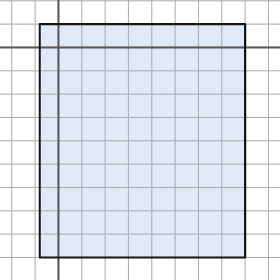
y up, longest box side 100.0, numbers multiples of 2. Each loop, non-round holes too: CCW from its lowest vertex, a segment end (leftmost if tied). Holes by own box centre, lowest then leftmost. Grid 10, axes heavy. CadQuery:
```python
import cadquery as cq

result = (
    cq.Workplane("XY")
    .moveTo(-8.0, -90.0)
    .lineTo(80.0, -90.0)
    .lineTo(80.0, 10.0)
    .lineTo(-8.0, 10.0)
    .close()
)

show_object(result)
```